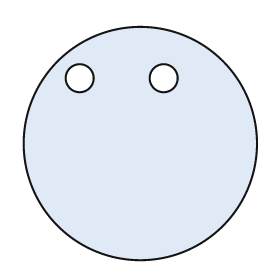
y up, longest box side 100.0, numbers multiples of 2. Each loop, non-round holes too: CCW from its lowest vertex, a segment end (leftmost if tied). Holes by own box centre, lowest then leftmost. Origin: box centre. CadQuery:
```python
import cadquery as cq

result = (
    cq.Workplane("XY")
    .moveTo(0.0, 0.0)
    .circle(50.0)
    .moveTo(-26.0, 28.0)
    .circle(6.0)
    .moveTo(10.0, 28.0)
    .circle(6.0)
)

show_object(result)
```